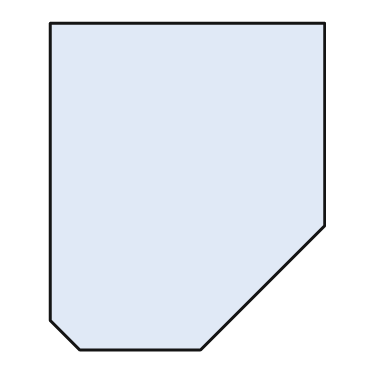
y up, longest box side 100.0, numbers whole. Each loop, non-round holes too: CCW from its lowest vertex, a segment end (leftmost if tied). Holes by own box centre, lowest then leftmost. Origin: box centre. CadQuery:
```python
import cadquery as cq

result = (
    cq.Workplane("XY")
    .moveTo(-33.0, -50.0)
    .lineTo(4.0, -50.0)
    .lineTo(42.0, -12.0)
    .lineTo(42.0, 50.0)
    .lineTo(-42.0, 50.0)
    .lineTo(-42.0, -41.0)
    .close()
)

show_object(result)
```